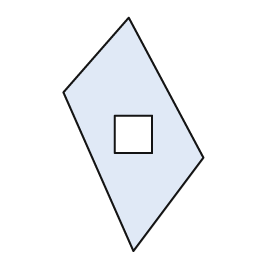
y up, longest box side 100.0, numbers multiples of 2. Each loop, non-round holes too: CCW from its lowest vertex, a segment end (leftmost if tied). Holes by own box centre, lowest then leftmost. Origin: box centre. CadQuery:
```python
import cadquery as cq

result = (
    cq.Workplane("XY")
    .moveTo(0.0, -50.0)
    .lineTo(30.0, -10.0)
    .lineTo(-2.0, 50.0)
    .lineTo(-30.0, 18.0)
    .close()
    .moveTo(-8.0, -8.0)
    .lineTo(8.0, -8.0)
    .lineTo(8.0, 8.0)
    .lineTo(-8.0, 8.0)
    .close()
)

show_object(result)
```